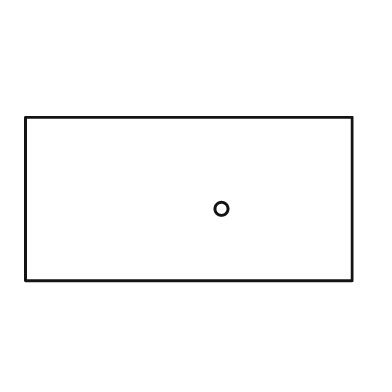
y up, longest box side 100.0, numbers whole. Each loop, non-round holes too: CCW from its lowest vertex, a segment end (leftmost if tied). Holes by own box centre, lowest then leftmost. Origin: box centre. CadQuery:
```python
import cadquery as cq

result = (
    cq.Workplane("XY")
    .moveTo(-50.0, -25.0)
    .lineTo(50.0, -25.0)
    .lineTo(50.0, 25.0)
    .lineTo(-50.0, 25.0)
    .close()
    .moveTo(10.0, -3.0)
    .circle(2.0)
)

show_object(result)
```